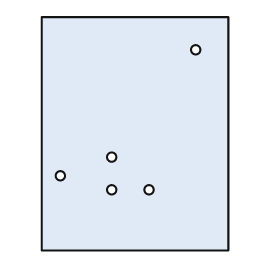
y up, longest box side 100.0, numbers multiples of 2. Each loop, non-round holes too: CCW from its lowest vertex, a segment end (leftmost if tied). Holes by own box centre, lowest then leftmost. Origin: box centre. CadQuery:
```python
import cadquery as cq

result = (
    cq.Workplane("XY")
    .moveTo(-40.0, -50.0)
    .lineTo(40.0, -50.0)
    .lineTo(40.0, 50.0)
    .lineTo(-40.0, 50.0)
    .close()
    .moveTo(-10.0, -24.0)
    .circle(2.0)
    .moveTo(6.0, -24.0)
    .circle(2.0)
    .moveTo(-32.0, -18.0)
    .circle(2.0)
    .moveTo(-10.0, -10.0)
    .circle(2.0)
    .moveTo(26.0, 36.0)
    .circle(2.0)
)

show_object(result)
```